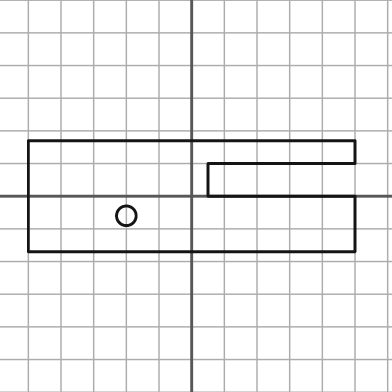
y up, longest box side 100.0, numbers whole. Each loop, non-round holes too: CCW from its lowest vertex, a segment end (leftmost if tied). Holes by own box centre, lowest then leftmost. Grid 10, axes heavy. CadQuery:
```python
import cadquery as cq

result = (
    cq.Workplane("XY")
    .moveTo(-50.0, -17.0)
    .lineTo(50.0, -17.0)
    .lineTo(50.0, 0.0)
    .lineTo(5.0, 0.0)
    .lineTo(5.0, 10.0)
    .lineTo(50.0, 10.0)
    .lineTo(50.0, 17.0)
    .lineTo(-50.0, 17.0)
    .close()
    .moveTo(-20.0, -6.0)
    .circle(3.0)
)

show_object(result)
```